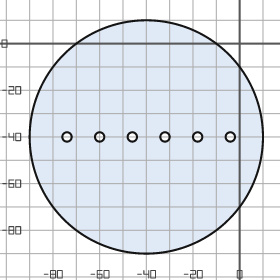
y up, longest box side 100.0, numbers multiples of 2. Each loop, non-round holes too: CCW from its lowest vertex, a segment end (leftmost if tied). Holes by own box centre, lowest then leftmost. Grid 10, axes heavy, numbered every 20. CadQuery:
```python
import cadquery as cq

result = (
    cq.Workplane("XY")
    .moveTo(-40.0, -40.0)
    .circle(50.0)
    .moveTo(-74.0, -40.0)
    .circle(2.0)
    .moveTo(-60.0, -40.0)
    .circle(2.0)
    .moveTo(-46.0, -40.0)
    .circle(2.0)
    .moveTo(-32.0, -40.0)
    .circle(2.0)
    .moveTo(-18.0, -40.0)
    .circle(2.0)
    .moveTo(-4.0, -40.0)
    .circle(2.0)
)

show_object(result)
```